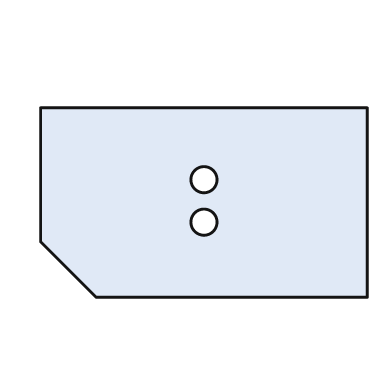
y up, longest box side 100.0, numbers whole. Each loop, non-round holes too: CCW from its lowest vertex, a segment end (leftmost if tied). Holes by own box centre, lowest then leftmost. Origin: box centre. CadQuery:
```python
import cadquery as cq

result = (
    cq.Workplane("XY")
    .moveTo(-33.0, -29.0)
    .lineTo(50.0, -29.0)
    .lineTo(50.0, 29.0)
    .lineTo(-50.0, 29.0)
    .lineTo(-50.0, -12.0)
    .close()
    .moveTo(0.0, -6.0)
    .circle(4.0)
    .moveTo(0.0, 7.0)
    .circle(4.0)
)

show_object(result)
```